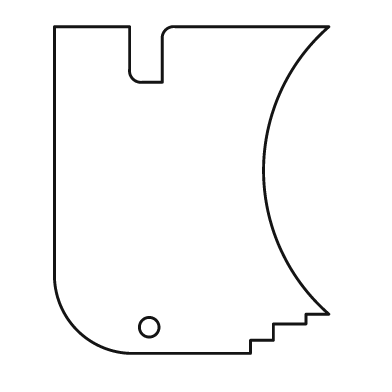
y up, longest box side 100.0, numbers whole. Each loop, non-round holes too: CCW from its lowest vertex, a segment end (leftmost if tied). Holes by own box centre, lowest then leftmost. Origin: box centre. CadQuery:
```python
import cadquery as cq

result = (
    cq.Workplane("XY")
    .moveTo(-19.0, -50.0)
    .lineTo(18.0, -50.0)
    .lineTo(18.0, -46.0)
    .lineTo(25.0, -46.0)
    .lineTo(25.0, -41.0)
    .lineTo(35.0, -41.0)
    .lineTo(35.0, -38.0)
    .lineTo(42.0, -38.0)
    .threePointArc((22.0, 6.0), (42.0, 50.0))
    .lineTo(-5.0, 50.0)
    .threePointArc((-8.0, 49.0), (-9.0, 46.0))
    .lineTo(-9.0, 33.0)
    .lineTo(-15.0, 33.0)
    .threePointArc((-18.0, 34.0), (-19.0, 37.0))
    .lineTo(-19.0, 50.0)
    .lineTo(-42.0, 50.0)
    .lineTo(-42.0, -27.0)
    .threePointArc((-35.0, -43.0), (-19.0, -50.0))
    .close()
    .moveTo(-13.0, -42.0)
    .circle(3.0)
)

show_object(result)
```